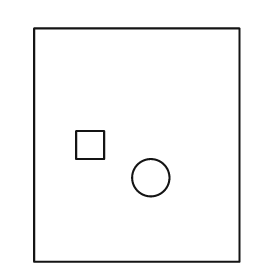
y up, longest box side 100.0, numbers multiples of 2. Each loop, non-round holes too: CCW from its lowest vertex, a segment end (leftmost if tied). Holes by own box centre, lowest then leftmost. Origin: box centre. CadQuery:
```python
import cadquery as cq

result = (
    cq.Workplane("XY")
    .moveTo(-44.0, -50.0)
    .lineTo(44.0, -50.0)
    .lineTo(44.0, 50.0)
    .lineTo(-44.0, 50.0)
    .close()
    .moveTo(6.0, -14.0)
    .circle(8.0)
    .moveTo(-26.0, -6.0)
    .lineTo(-14.0, -6.0)
    .lineTo(-14.0, 6.0)
    .lineTo(-26.0, 6.0)
    .close()
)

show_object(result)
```